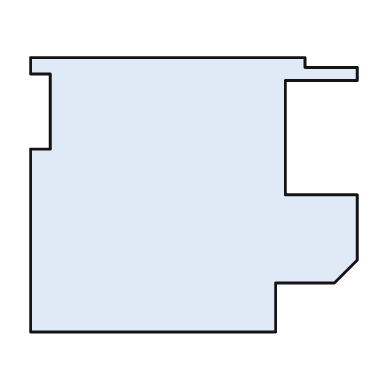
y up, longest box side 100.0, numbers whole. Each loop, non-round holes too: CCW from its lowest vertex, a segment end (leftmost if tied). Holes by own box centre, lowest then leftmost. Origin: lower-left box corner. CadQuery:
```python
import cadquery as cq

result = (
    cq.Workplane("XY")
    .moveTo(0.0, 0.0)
    .lineTo(75.0, 0.0)
    .lineTo(75.0, 15.0)
    .lineTo(93.0, 15.0)
    .lineTo(100.0, 22.0)
    .lineTo(100.0, 42.0)
    .lineTo(78.0, 42.0)
    .lineTo(78.0, 77.0)
    .lineTo(100.0, 77.0)
    .lineTo(100.0, 81.0)
    .lineTo(84.0, 81.0)
    .lineTo(84.0, 84.0)
    .lineTo(0.0, 84.0)
    .lineTo(0.0, 79.0)
    .lineTo(6.0, 79.0)
    .lineTo(6.0, 56.0)
    .lineTo(0.0, 56.0)
    .close()
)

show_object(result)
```